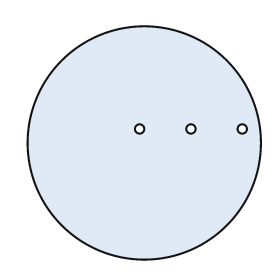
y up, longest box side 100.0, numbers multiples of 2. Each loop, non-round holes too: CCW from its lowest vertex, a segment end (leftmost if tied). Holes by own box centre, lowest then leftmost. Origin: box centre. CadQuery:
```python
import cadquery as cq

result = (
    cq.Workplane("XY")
    .moveTo(0.0, 0.0)
    .circle(50.0)
    .moveTo(-2.0, 6.0)
    .circle(2.0)
    .moveTo(20.0, 6.0)
    .circle(2.0)
    .moveTo(42.0, 6.0)
    .circle(2.0)
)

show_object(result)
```